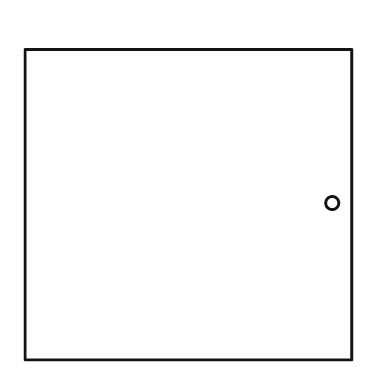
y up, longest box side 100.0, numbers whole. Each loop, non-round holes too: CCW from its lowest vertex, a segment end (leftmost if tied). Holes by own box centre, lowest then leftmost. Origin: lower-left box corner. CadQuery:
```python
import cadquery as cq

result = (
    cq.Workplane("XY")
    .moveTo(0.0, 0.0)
    .lineTo(100.0, 0.0)
    .lineTo(100.0, 95.0)
    .lineTo(0.0, 95.0)
    .close()
    .moveTo(94.0, 48.0)
    .circle(2.0)
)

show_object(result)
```